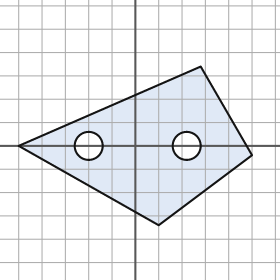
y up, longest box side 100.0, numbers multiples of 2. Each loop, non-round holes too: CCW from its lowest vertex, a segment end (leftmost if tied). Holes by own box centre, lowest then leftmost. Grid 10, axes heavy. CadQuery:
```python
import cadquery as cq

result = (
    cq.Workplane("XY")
    .moveTo(10.0, -34.0)
    .lineTo(50.0, -4.0)
    .lineTo(28.0, 34.0)
    .lineTo(-50.0, 0.0)
    .close()
    .moveTo(-20.0, 0.0)
    .circle(6.0)
    .moveTo(22.0, 0.0)
    .circle(6.0)
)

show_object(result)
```